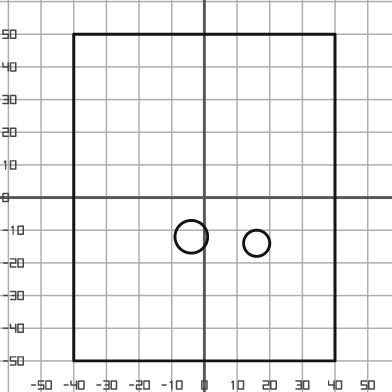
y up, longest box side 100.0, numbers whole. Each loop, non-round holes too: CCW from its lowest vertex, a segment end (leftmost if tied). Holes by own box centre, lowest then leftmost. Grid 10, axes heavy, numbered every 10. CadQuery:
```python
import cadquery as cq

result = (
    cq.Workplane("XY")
    .moveTo(-40.0, -50.0)
    .lineTo(40.0, -50.0)
    .lineTo(40.0, 50.0)
    .lineTo(-40.0, 50.0)
    .close()
    .moveTo(16.0, -14.0)
    .circle(4.0)
    .moveTo(-4.0, -12.0)
    .circle(5.0)
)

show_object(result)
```